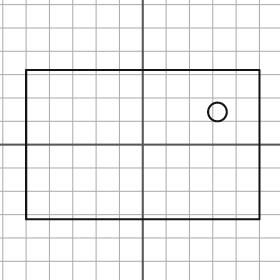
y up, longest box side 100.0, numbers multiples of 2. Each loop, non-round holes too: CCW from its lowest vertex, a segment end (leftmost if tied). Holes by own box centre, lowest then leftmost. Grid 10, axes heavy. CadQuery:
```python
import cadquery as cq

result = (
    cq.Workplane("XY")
    .moveTo(-50.0, -32.0)
    .lineTo(50.0, -32.0)
    .lineTo(50.0, 32.0)
    .lineTo(-50.0, 32.0)
    .close()
    .moveTo(32.0, 14.0)
    .circle(4.0)
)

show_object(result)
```